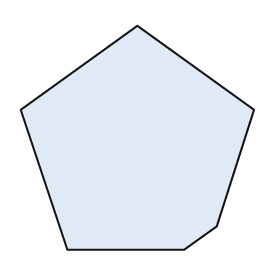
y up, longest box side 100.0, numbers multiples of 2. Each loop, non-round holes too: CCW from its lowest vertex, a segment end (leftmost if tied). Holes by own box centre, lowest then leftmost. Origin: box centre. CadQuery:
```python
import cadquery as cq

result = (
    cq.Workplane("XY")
    .moveTo(-30.0, -48.0)
    .lineTo(20.0, -48.0)
    .lineTo(34.0, -38.0)
    .lineTo(50.0, 12.0)
    .lineTo(0.0, 48.0)
    .lineTo(-50.0, 12.0)
    .close()
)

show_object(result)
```